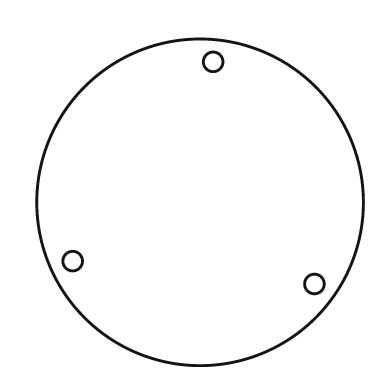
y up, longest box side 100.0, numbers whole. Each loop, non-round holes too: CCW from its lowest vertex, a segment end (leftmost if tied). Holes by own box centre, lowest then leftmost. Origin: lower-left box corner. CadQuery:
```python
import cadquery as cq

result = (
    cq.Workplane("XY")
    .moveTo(50.0, 50.0)
    .circle(50.0)
    .moveTo(85.0, 25.0)
    .circle(3.0)
    .moveTo(11.0, 32.0)
    .circle(3.0)
    .moveTo(54.0, 93.0)
    .circle(3.0)
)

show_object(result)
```